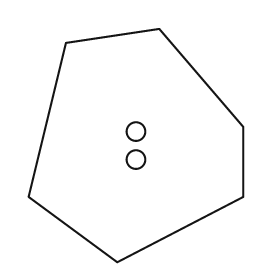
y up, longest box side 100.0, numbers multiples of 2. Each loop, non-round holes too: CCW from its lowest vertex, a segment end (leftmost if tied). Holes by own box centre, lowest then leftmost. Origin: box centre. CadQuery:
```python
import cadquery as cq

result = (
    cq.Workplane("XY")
    .moveTo(-8.0, -50.0)
    .lineTo(46.0, -22.0)
    .lineTo(46.0, 8.0)
    .lineTo(10.0, 50.0)
    .lineTo(-30.0, 44.0)
    .lineTo(-46.0, -22.0)
    .close()
    .moveTo(0.0, -6.0)
    .circle(4.0)
    .moveTo(0.0, 6.0)
    .circle(4.0)
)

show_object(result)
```